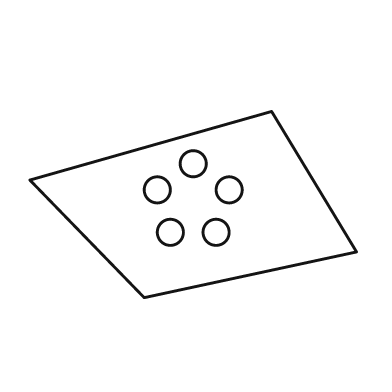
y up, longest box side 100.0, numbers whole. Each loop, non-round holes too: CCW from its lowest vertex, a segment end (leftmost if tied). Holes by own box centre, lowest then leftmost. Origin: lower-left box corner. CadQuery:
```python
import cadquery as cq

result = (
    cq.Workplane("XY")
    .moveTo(35.0, 0.0)
    .lineTo(100.0, 14.0)
    .lineTo(74.0, 57.0)
    .lineTo(0.0, 36.0)
    .close()
    .moveTo(43.0, 20.0)
    .circle(4.0)
    .moveTo(57.0, 20.0)
    .circle(4.0)
    .moveTo(39.0, 33.0)
    .circle(4.0)
    .moveTo(61.0, 33.0)
    .circle(4.0)
    .moveTo(50.0, 41.0)
    .circle(4.0)
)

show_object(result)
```